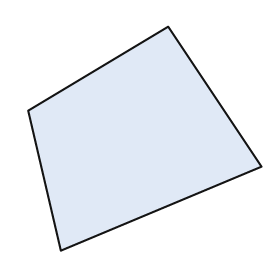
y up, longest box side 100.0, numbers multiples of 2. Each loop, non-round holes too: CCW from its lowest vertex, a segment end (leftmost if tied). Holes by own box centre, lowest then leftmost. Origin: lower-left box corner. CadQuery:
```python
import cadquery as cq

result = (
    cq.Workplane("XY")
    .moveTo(14.0, 0.0)
    .lineTo(100.0, 36.0)
    .lineTo(60.0, 96.0)
    .lineTo(0.0, 60.0)
    .close()
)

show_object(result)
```